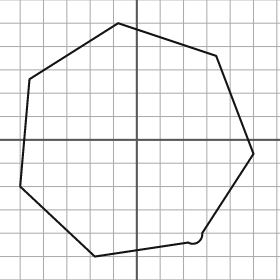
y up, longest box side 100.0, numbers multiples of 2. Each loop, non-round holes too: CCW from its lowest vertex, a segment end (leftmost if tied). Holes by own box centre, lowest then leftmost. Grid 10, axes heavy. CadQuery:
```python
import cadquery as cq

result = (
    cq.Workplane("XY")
    .moveTo(-18.0, -50.0)
    .lineTo(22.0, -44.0)
    .threePointArc((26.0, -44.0), (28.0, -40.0))
    .lineTo(50.0, -6.0)
    .lineTo(34.0, 36.0)
    .lineTo(-8.0, 50.0)
    .lineTo(-46.0, 26.0)
    .lineTo(-50.0, -20.0)
    .close()
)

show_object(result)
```